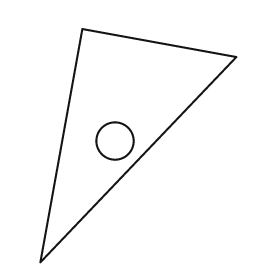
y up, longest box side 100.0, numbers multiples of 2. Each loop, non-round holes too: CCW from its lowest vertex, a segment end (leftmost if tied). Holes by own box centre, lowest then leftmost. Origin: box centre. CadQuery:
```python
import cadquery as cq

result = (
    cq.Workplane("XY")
    .moveTo(-42.0, -50.0)
    .lineTo(42.0, 38.0)
    .lineTo(-24.0, 50.0)
    .close()
    .moveTo(-10.0, 2.0)
    .circle(8.0)
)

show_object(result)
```